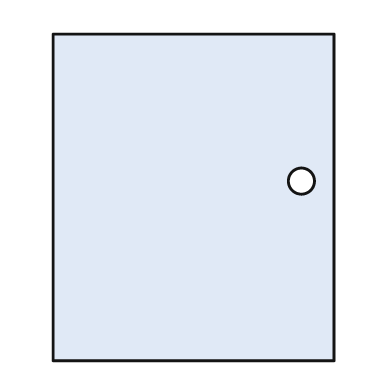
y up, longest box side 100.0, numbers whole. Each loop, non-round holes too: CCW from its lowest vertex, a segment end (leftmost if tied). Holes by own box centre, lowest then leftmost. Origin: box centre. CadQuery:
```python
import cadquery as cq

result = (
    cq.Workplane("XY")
    .moveTo(-43.0, -50.0)
    .lineTo(43.0, -50.0)
    .lineTo(43.0, 50.0)
    .lineTo(-43.0, 50.0)
    .close()
    .moveTo(33.0, 5.0)
    .circle(4.0)
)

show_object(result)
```